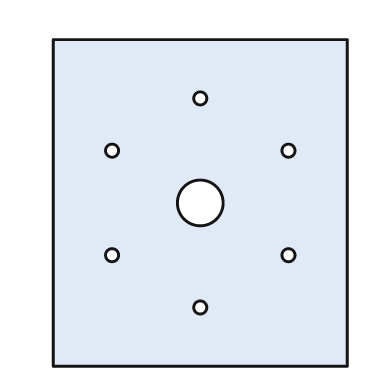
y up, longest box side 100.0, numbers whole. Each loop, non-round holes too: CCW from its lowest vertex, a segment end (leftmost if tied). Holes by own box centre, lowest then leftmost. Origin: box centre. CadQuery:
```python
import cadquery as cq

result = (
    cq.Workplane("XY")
    .moveTo(-45.0, -50.0)
    .lineTo(45.0, -50.0)
    .lineTo(45.0, 50.0)
    .lineTo(-45.0, 50.0)
    .close()
    .moveTo(0.0, -32.0)
    .circle(2.0)
    .moveTo(-27.0, -16.0)
    .circle(2.0)
    .moveTo(27.0, -16.0)
    .circle(2.0)
    .moveTo(0.0, 0.0)
    .circle(7.0)
    .moveTo(-27.0, 16.0)
    .circle(2.0)
    .moveTo(27.0, 16.0)
    .circle(2.0)
    .moveTo(0.0, 32.0)
    .circle(2.0)
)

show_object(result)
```